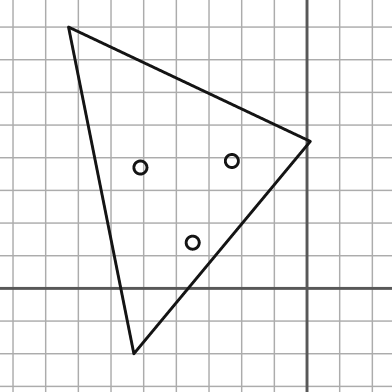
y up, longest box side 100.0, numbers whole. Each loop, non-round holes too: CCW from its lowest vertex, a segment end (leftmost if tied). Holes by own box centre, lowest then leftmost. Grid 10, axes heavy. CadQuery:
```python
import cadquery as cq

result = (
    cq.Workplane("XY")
    .moveTo(-53.0, -20.0)
    .lineTo(1.0, 45.0)
    .lineTo(-73.0, 80.0)
    .close()
    .moveTo(-35.0, 14.0)
    .circle(2.0)
    .moveTo(-51.0, 37.0)
    .circle(2.0)
    .moveTo(-23.0, 39.0)
    .circle(2.0)
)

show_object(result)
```